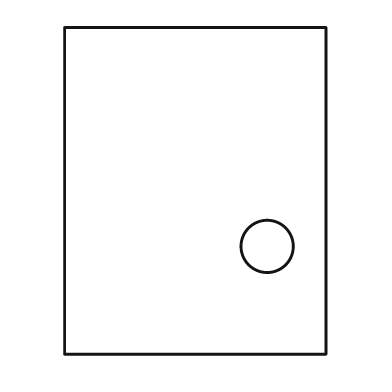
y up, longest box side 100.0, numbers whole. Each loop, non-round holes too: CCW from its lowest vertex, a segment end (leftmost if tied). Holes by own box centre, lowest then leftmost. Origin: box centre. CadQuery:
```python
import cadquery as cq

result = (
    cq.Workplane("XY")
    .moveTo(-40.0, -50.0)
    .lineTo(40.0, -50.0)
    .lineTo(40.0, 50.0)
    .lineTo(-40.0, 50.0)
    .close()
    .moveTo(22.0, -17.0)
    .circle(8.0)
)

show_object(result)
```